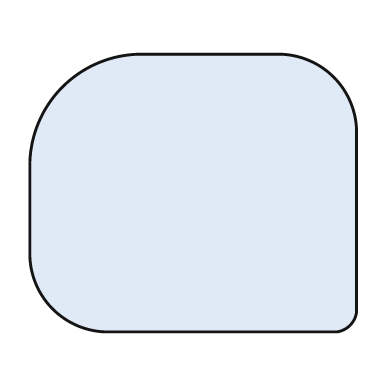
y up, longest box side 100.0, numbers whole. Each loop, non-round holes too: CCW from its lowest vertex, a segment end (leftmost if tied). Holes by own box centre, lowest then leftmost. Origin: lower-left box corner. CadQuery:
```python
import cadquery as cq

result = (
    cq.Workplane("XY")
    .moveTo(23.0, 0.0)
    .lineTo(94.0, 0.0)
    .threePointArc((98.0, 2.0), (100.0, 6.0))
    .lineTo(100.0, 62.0)
    .threePointArc((93.0, 78.0), (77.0, 85.0))
    .lineTo(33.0, 85.0)
    .threePointArc((10.0, 75.0), (0.0, 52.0))
    .lineTo(0.0, 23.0)
    .threePointArc((7.0, 7.0), (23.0, 0.0))
    .close()
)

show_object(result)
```